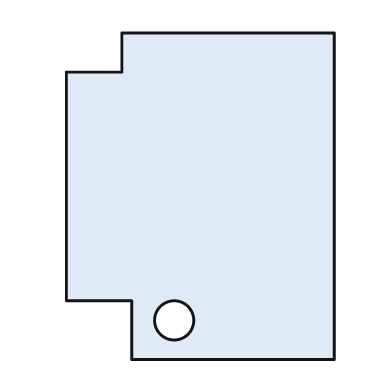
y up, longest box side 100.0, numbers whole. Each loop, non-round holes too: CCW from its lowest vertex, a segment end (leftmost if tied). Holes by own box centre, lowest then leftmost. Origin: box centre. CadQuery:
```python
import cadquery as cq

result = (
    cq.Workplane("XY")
    .moveTo(-21.0, -50.0)
    .lineTo(41.0, -50.0)
    .lineTo(41.0, 50.0)
    .lineTo(-24.0, 50.0)
    .lineTo(-24.0, 38.0)
    .lineTo(-41.0, 38.0)
    .lineTo(-41.0, -32.0)
    .lineTo(-21.0, -32.0)
    .close()
    .moveTo(-8.0, -38.0)
    .circle(6.0)
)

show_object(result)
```